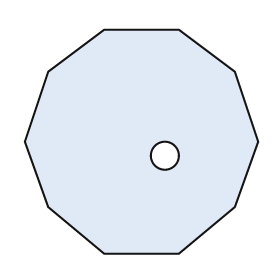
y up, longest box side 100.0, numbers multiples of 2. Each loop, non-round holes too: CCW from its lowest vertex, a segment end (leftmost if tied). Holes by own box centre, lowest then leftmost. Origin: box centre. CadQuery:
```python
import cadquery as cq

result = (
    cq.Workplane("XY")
    .moveTo(-16.0, -48.0)
    .lineTo(16.0, -48.0)
    .lineTo(40.0, -28.0)
    .lineTo(50.0, 0.0)
    .lineTo(40.0, 30.0)
    .lineTo(16.0, 48.0)
    .lineTo(-16.0, 48.0)
    .lineTo(-40.0, 30.0)
    .lineTo(-50.0, 0.0)
    .lineTo(-40.0, -28.0)
    .close()
    .moveTo(10.0, -6.0)
    .circle(6.0)
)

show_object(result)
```